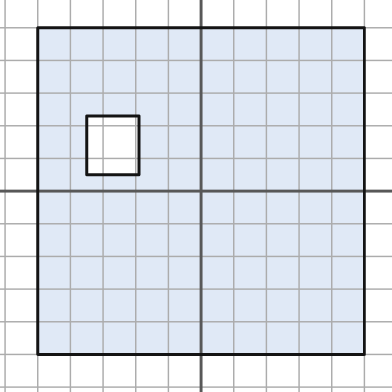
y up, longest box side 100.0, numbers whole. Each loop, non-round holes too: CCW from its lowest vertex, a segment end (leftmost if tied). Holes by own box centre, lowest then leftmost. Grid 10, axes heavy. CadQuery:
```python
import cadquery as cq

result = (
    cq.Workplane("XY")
    .moveTo(-50.0, -50.0)
    .lineTo(50.0, -50.0)
    .lineTo(50.0, 50.0)
    .lineTo(-50.0, 50.0)
    .close()
    .moveTo(-35.0, 5.0)
    .lineTo(-19.0, 5.0)
    .lineTo(-19.0, 23.0)
    .lineTo(-35.0, 23.0)
    .close()
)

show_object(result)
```